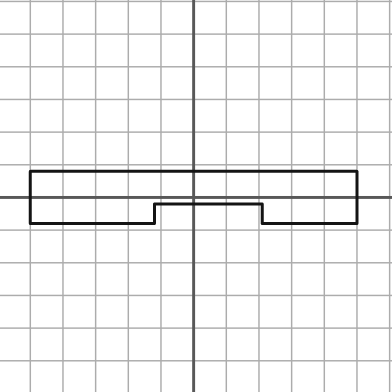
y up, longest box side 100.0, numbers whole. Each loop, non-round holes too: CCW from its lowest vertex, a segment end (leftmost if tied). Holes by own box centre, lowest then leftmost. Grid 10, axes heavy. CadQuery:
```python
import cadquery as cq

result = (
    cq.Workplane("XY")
    .moveTo(-50.0, -8.0)
    .lineTo(-12.0, -8.0)
    .lineTo(-12.0, -2.0)
    .lineTo(21.0, -2.0)
    .lineTo(21.0, -8.0)
    .lineTo(50.0, -8.0)
    .lineTo(50.0, 8.0)
    .lineTo(-50.0, 8.0)
    .close()
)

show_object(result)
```